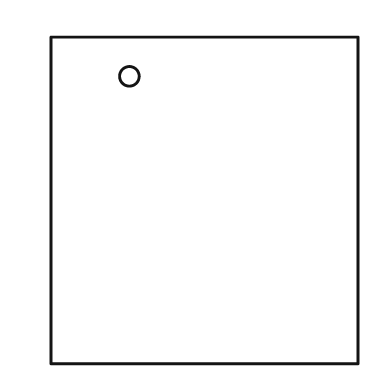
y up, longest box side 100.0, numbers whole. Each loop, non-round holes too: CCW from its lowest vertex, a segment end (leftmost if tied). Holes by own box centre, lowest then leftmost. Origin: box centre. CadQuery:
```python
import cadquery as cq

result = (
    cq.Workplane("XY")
    .moveTo(-47.0, -50.0)
    .lineTo(47.0, -50.0)
    .lineTo(47.0, 50.0)
    .lineTo(-47.0, 50.0)
    .close()
    .moveTo(-23.0, 38.0)
    .circle(3.0)
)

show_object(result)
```